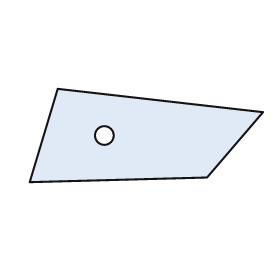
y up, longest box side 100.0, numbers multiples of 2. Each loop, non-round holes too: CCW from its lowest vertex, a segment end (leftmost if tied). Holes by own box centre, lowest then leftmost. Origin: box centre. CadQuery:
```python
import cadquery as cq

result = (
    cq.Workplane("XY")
    .moveTo(-50.0, -20.0)
    .lineTo(26.0, -18.0)
    .lineTo(50.0, 10.0)
    .lineTo(-38.0, 20.0)
    .close()
    .moveTo(-18.0, 0.0)
    .circle(4.0)
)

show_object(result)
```